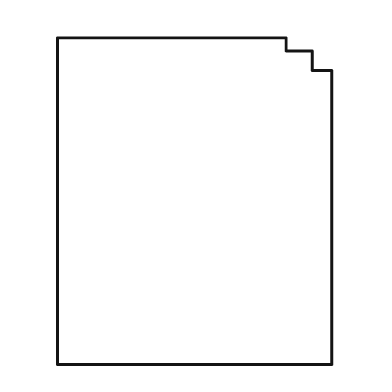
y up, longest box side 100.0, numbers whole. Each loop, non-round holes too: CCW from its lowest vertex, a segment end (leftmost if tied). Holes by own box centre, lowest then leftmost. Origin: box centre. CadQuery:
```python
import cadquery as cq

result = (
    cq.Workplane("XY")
    .moveTo(-42.0, -50.0)
    .lineTo(42.0, -50.0)
    .lineTo(42.0, 40.0)
    .lineTo(36.0, 40.0)
    .lineTo(36.0, 46.0)
    .lineTo(28.0, 46.0)
    .lineTo(28.0, 50.0)
    .lineTo(-42.0, 50.0)
    .close()
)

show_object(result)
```